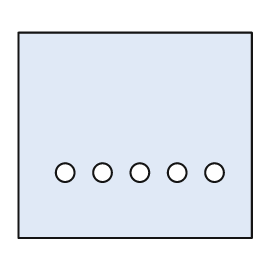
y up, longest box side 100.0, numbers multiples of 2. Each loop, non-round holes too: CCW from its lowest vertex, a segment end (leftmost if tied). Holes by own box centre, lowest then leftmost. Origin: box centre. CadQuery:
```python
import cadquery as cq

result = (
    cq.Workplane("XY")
    .moveTo(-50.0, -44.0)
    .lineTo(50.0, -44.0)
    .lineTo(50.0, 44.0)
    .lineTo(-50.0, 44.0)
    .close()
    .moveTo(-30.0, -16.0)
    .circle(4.0)
    .moveTo(-14.0, -16.0)
    .circle(4.0)
    .moveTo(2.0, -16.0)
    .circle(4.0)
    .moveTo(18.0, -16.0)
    .circle(4.0)
    .moveTo(34.0, -16.0)
    .circle(4.0)
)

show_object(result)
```